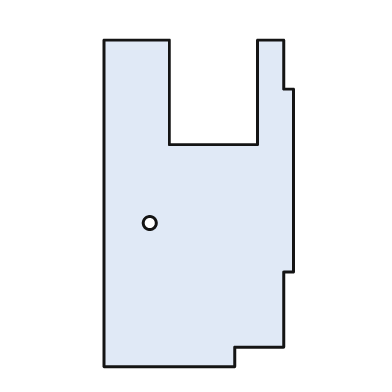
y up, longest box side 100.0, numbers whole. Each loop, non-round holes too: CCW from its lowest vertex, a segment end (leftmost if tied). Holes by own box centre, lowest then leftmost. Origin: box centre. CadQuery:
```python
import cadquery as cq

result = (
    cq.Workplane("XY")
    .moveTo(-29.0, -50.0)
    .lineTo(11.0, -50.0)
    .lineTo(11.0, -44.0)
    .lineTo(26.0, -44.0)
    .lineTo(26.0, -21.0)
    .lineTo(29.0, -21.0)
    .lineTo(29.0, 35.0)
    .lineTo(26.0, 35.0)
    .lineTo(26.0, 50.0)
    .lineTo(18.0, 50.0)
    .lineTo(18.0, 18.0)
    .lineTo(-9.0, 18.0)
    .lineTo(-9.0, 50.0)
    .lineTo(-29.0, 50.0)
    .close()
    .moveTo(-15.0, -6.0)
    .circle(2.0)
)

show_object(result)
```